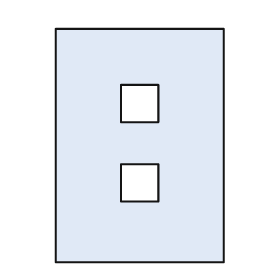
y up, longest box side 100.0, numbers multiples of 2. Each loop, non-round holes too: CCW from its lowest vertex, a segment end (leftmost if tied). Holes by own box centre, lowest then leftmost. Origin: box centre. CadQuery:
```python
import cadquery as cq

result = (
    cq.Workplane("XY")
    .moveTo(-36.0, -50.0)
    .lineTo(36.0, -50.0)
    .lineTo(36.0, 50.0)
    .lineTo(-36.0, 50.0)
    .close()
    .moveTo(-8.0, -24.0)
    .lineTo(8.0, -24.0)
    .lineTo(8.0, -8.0)
    .lineTo(-8.0, -8.0)
    .close()
    .moveTo(-8.0, 10.0)
    .lineTo(8.0, 10.0)
    .lineTo(8.0, 26.0)
    .lineTo(-8.0, 26.0)
    .close()
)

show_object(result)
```